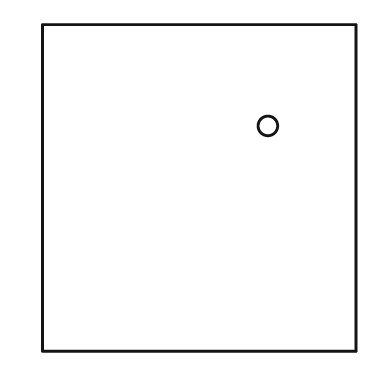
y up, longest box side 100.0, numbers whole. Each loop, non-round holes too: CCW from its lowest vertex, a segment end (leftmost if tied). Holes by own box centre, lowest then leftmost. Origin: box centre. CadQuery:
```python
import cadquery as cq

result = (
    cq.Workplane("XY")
    .moveTo(-48.0, -50.0)
    .lineTo(48.0, -50.0)
    .lineTo(48.0, 50.0)
    .lineTo(-48.0, 50.0)
    .close()
    .moveTo(21.0, 19.0)
    .circle(3.0)
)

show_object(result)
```